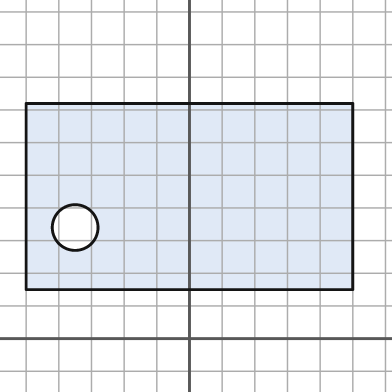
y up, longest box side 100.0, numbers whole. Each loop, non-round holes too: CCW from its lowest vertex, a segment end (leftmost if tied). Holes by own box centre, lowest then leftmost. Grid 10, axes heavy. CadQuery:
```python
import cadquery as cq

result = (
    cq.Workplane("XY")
    .moveTo(-50.0, 15.0)
    .lineTo(50.0, 15.0)
    .lineTo(50.0, 72.0)
    .lineTo(-50.0, 72.0)
    .close()
    .moveTo(-35.0, 34.0)
    .circle(7.0)
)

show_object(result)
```